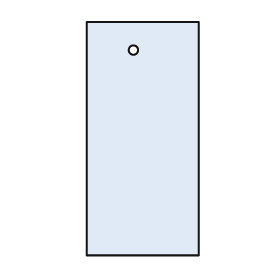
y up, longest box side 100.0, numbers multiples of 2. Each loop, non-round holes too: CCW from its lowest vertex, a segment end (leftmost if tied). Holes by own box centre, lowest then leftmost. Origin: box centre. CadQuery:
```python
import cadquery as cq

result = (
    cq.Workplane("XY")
    .moveTo(-24.0, -50.0)
    .lineTo(24.0, -50.0)
    .lineTo(24.0, 50.0)
    .lineTo(-24.0, 50.0)
    .close()
    .moveTo(-4.0, 38.0)
    .circle(2.0)
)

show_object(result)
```